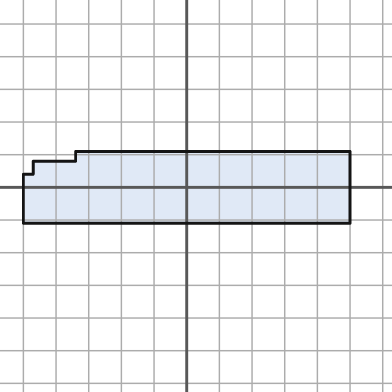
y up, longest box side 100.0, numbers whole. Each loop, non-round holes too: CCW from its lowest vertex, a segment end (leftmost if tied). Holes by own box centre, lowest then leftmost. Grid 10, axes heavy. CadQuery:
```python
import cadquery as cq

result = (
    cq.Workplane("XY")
    .moveTo(-50.0, -11.0)
    .lineTo(50.0, -11.0)
    .lineTo(50.0, 11.0)
    .lineTo(-34.0, 11.0)
    .lineTo(-34.0, 8.0)
    .lineTo(-47.0, 8.0)
    .lineTo(-47.0, 4.0)
    .lineTo(-50.0, 4.0)
    .close()
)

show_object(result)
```